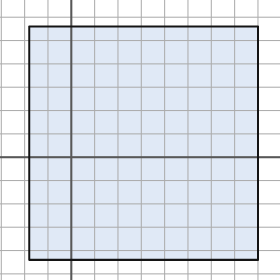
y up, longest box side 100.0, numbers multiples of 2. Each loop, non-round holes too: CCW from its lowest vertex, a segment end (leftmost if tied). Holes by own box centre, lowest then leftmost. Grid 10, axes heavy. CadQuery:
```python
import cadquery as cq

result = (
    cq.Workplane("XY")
    .moveTo(-18.0, -44.0)
    .lineTo(80.0, -44.0)
    .lineTo(80.0, 56.0)
    .lineTo(-18.0, 56.0)
    .close()
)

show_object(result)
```